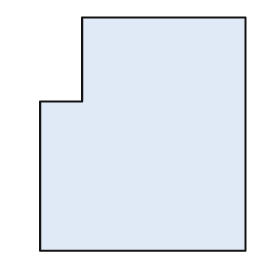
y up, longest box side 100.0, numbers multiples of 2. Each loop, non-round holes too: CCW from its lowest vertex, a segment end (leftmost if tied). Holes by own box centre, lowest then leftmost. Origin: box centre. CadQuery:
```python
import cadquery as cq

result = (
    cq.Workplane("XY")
    .moveTo(-44.0, -50.0)
    .lineTo(44.0, -50.0)
    .lineTo(44.0, 50.0)
    .lineTo(-26.0, 50.0)
    .lineTo(-26.0, 14.0)
    .lineTo(-44.0, 14.0)
    .close()
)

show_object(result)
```